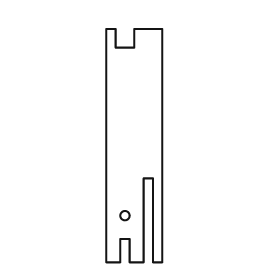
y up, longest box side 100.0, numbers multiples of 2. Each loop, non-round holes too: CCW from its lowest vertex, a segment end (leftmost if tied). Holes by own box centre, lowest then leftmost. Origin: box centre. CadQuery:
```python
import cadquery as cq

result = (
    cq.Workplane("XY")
    .moveTo(-12.0, -50.0)
    .lineTo(-6.0, -50.0)
    .lineTo(-6.0, -40.0)
    .lineTo(-2.0, -40.0)
    .lineTo(-2.0, -50.0)
    .lineTo(4.0, -50.0)
    .lineTo(4.0, -14.0)
    .lineTo(8.0, -14.0)
    .lineTo(8.0, -50.0)
    .lineTo(12.0, -50.0)
    .lineTo(12.0, 50.0)
    .lineTo(0.0, 50.0)
    .lineTo(0.0, 42.0)
    .lineTo(-8.0, 42.0)
    .lineTo(-8.0, 50.0)
    .lineTo(-12.0, 50.0)
    .close()
    .moveTo(-4.0, -30.0)
    .circle(2.0)
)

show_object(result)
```